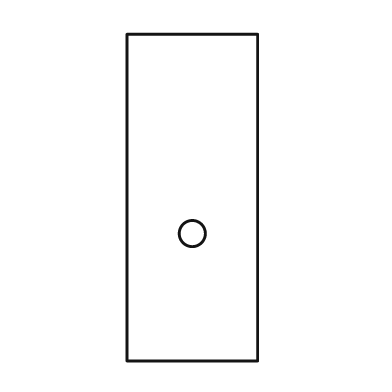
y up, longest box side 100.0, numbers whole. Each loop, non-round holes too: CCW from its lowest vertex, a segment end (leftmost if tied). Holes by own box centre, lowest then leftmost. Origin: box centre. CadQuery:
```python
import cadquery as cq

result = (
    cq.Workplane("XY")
    .moveTo(-20.0, -50.0)
    .lineTo(20.0, -50.0)
    .lineTo(20.0, 50.0)
    .lineTo(-20.0, 50.0)
    .close()
    .moveTo(0.0, -11.0)
    .circle(4.0)
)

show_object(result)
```